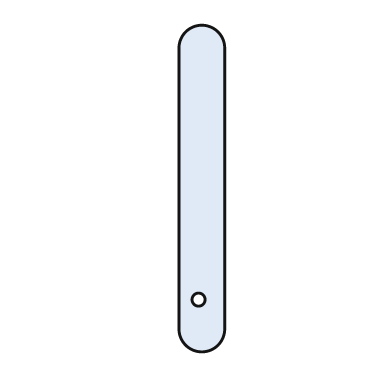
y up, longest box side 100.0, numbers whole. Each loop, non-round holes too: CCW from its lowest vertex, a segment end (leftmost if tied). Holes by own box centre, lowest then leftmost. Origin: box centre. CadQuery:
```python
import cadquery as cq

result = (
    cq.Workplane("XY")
    .moveTo(-7.0, -43.0)
    .threePointArc((0.0, -50.0), (7.0, -43.0))
    .lineTo(7.0, 43.0)
    .threePointArc((0.0, 50.0), (-7.0, 43.0))
    .close()
    .moveTo(-1.0, -34.0)
    .circle(2.0)
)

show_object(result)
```